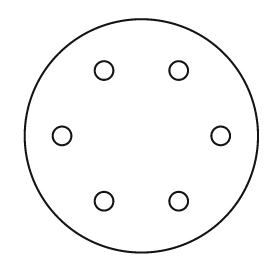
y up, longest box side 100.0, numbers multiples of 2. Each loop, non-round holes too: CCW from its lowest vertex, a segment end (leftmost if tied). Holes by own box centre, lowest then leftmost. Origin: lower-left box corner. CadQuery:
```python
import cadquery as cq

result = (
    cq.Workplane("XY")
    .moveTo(50.0, 50.0)
    .circle(50.0)
    .moveTo(34.0, 22.0)
    .circle(4.0)
    .moveTo(66.0, 22.0)
    .circle(4.0)
    .moveTo(16.0, 50.0)
    .circle(4.0)
    .moveTo(84.0, 50.0)
    .circle(4.0)
    .moveTo(34.0, 78.0)
    .circle(4.0)
    .moveTo(66.0, 78.0)
    .circle(4.0)
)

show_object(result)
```